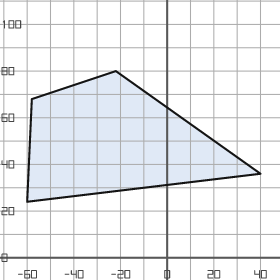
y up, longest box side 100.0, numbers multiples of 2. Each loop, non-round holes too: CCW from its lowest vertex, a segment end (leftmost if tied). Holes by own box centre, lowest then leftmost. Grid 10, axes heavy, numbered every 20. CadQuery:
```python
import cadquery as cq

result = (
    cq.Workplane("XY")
    .moveTo(-60.0, 24.0)
    .lineTo(40.0, 36.0)
    .lineTo(-22.0, 80.0)
    .lineTo(-58.0, 68.0)
    .close()
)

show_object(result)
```